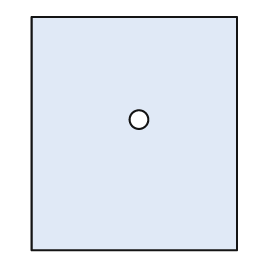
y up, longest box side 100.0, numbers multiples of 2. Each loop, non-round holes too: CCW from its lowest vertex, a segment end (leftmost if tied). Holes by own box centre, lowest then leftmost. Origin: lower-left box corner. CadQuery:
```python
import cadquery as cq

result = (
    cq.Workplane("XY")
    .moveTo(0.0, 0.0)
    .lineTo(88.0, 0.0)
    .lineTo(88.0, 100.0)
    .lineTo(0.0, 100.0)
    .close()
    .moveTo(46.0, 56.0)
    .circle(4.0)
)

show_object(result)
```